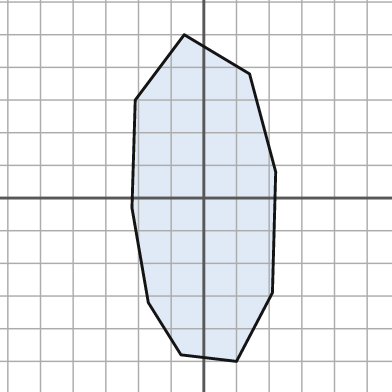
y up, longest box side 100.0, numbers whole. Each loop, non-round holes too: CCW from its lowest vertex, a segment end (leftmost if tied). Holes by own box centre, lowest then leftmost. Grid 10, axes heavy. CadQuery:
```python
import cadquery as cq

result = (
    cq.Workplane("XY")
    .moveTo(10.0, -50.0)
    .lineTo(21.0, -29.0)
    .lineTo(22.0, 8.0)
    .lineTo(14.0, 38.0)
    .lineTo(-6.0, 50.0)
    .lineTo(-21.0, 30.0)
    .lineTo(-22.0, -3.0)
    .lineTo(-17.0, -32.0)
    .lineTo(-7.0, -48.0)
    .close()
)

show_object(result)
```